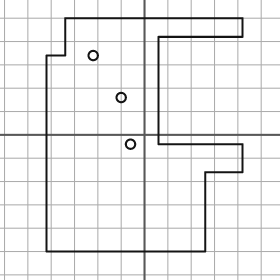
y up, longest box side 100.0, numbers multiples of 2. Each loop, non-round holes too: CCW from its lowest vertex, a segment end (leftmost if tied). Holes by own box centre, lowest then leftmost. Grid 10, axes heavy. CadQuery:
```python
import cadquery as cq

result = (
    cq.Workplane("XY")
    .moveTo(-42.0, -50.0)
    .lineTo(26.0, -50.0)
    .lineTo(26.0, -16.0)
    .lineTo(42.0, -16.0)
    .lineTo(42.0, -4.0)
    .lineTo(6.0, -4.0)
    .lineTo(6.0, 42.0)
    .lineTo(42.0, 42.0)
    .lineTo(42.0, 50.0)
    .lineTo(-34.0, 50.0)
    .lineTo(-34.0, 34.0)
    .lineTo(-42.0, 34.0)
    .close()
    .moveTo(-6.0, -4.0)
    .circle(2.0)
    .moveTo(-10.0, 16.0)
    .circle(2.0)
    .moveTo(-22.0, 34.0)
    .circle(2.0)
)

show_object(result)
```